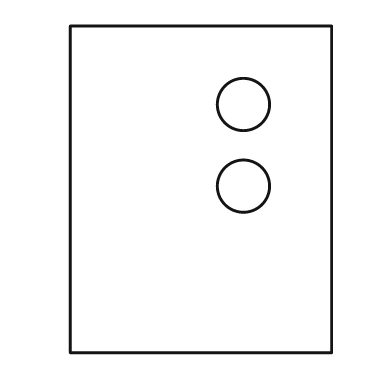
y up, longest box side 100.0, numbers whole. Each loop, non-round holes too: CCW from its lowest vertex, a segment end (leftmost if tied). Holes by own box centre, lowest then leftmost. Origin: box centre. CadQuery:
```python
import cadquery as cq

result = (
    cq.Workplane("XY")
    .moveTo(-40.0, -50.0)
    .lineTo(40.0, -50.0)
    .lineTo(40.0, 50.0)
    .lineTo(-40.0, 50.0)
    .close()
    .moveTo(13.0, 1.0)
    .circle(8.0)
    .moveTo(13.0, 26.0)
    .circle(8.0)
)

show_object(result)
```